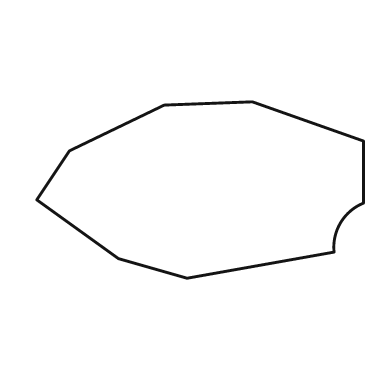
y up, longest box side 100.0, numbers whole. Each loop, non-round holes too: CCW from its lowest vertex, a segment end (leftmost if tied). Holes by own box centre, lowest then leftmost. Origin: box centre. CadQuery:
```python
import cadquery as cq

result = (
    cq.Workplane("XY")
    .moveTo(-4.0, -27.0)
    .lineTo(41.0, -19.0)
    .threePointArc((43.0, -10.0), (50.0, -4.0))
    .lineTo(50.0, 15.0)
    .lineTo(16.0, 27.0)
    .lineTo(-11.0, 26.0)
    .lineTo(-40.0, 12.0)
    .lineTo(-50.0, -3.0)
    .lineTo(-25.0, -21.0)
    .close()
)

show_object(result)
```